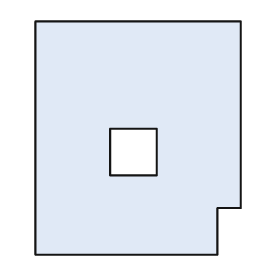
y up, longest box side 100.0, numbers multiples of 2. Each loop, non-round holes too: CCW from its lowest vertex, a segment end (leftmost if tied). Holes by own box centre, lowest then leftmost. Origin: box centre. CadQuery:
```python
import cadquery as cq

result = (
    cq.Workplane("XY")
    .moveTo(-44.0, -50.0)
    .lineTo(34.0, -50.0)
    .lineTo(34.0, -30.0)
    .lineTo(44.0, -30.0)
    .lineTo(44.0, 50.0)
    .lineTo(-44.0, 50.0)
    .close()
    .moveTo(-12.0, -16.0)
    .lineTo(8.0, -16.0)
    .lineTo(8.0, 4.0)
    .lineTo(-12.0, 4.0)
    .close()
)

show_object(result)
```